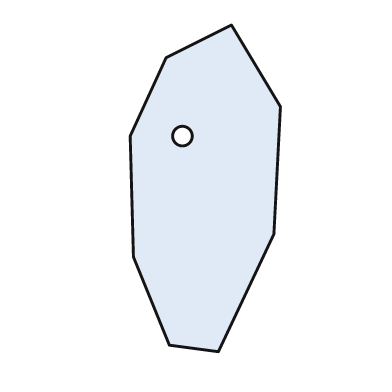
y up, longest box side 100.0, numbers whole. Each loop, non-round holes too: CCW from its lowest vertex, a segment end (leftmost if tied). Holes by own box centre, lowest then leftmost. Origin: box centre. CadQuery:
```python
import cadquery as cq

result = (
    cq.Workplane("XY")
    .moveTo(4.0, -50.0)
    .lineTo(21.0, -14.0)
    .lineTo(23.0, 25.0)
    .lineTo(8.0, 50.0)
    .lineTo(-12.0, 40.0)
    .lineTo(-23.0, 16.0)
    .lineTo(-22.0, -21.0)
    .lineTo(-11.0, -48.0)
    .close()
    .moveTo(-7.0, 16.0)
    .circle(3.0)
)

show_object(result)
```